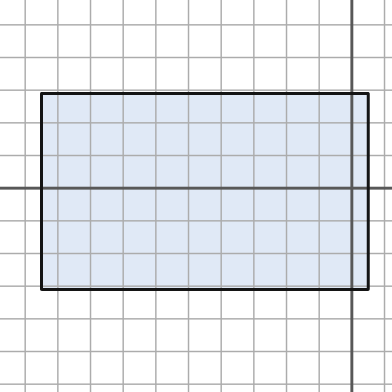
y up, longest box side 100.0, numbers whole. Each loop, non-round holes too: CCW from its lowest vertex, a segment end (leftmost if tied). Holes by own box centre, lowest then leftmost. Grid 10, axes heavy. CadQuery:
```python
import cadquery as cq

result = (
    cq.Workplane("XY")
    .moveTo(-95.0, -31.0)
    .lineTo(5.0, -31.0)
    .lineTo(5.0, 29.0)
    .lineTo(-95.0, 29.0)
    .close()
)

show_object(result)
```